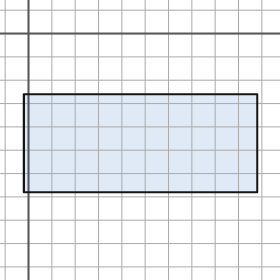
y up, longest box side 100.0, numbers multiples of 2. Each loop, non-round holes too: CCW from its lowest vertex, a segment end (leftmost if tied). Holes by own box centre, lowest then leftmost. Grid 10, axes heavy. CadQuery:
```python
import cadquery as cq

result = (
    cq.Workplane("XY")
    .moveTo(-2.0, -68.0)
    .lineTo(98.0, -68.0)
    .lineTo(98.0, -26.0)
    .lineTo(-2.0, -26.0)
    .close()
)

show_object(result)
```